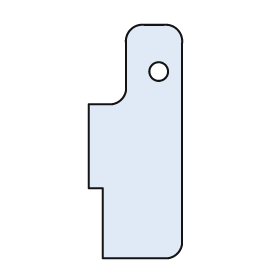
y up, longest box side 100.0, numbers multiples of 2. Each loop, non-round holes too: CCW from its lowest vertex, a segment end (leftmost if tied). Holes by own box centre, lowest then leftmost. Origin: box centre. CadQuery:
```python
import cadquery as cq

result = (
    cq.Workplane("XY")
    .moveTo(-14.0, -50.0)
    .lineTo(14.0, -50.0)
    .threePointArc((18.0, -48.0), (20.0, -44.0))
    .lineTo(20.0, 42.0)
    .threePointArc((18.0, 48.0), (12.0, 50.0))
    .lineTo(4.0, 50.0)
    .threePointArc((-2.0, 48.0), (-4.0, 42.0))
    .lineTo(-4.0, 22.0)
    .threePointArc((-6.0, 18.0), (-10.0, 16.0))
    .lineTo(-20.0, 16.0)
    .lineTo(-20.0, -20.0)
    .lineTo(-14.0, -20.0)
    .close()
    .moveTo(10.0, 30.0)
    .circle(4.0)
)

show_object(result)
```